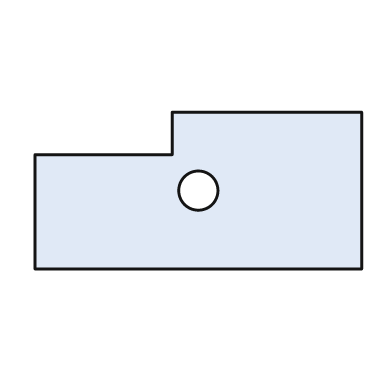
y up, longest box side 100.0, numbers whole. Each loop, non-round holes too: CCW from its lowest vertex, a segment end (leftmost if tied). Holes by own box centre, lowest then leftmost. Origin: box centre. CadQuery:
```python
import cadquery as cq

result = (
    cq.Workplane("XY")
    .moveTo(-50.0, -24.0)
    .lineTo(50.0, -24.0)
    .lineTo(50.0, 24.0)
    .lineTo(-8.0, 24.0)
    .lineTo(-8.0, 11.0)
    .lineTo(-50.0, 11.0)
    .close()
    .moveTo(0.0, 0.0)
    .circle(6.0)
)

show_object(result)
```